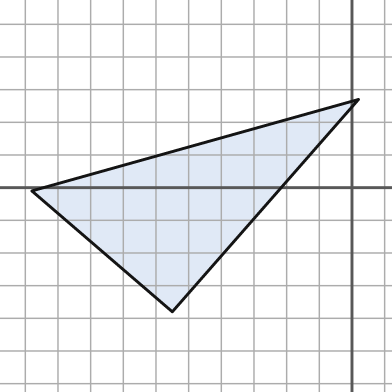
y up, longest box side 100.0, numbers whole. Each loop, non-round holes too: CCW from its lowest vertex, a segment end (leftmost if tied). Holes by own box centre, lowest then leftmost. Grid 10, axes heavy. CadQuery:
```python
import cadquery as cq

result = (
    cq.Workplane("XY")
    .moveTo(-55.0, -38.0)
    .lineTo(2.0, 27.0)
    .lineTo(-98.0, -1.0)
    .close()
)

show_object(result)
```